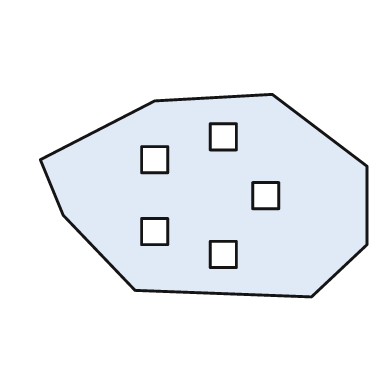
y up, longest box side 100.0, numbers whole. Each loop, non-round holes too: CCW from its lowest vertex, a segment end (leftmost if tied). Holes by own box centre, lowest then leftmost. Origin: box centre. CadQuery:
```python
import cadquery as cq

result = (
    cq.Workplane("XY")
    .moveTo(33.0, -31.0)
    .lineTo(50.0, -15.0)
    .lineTo(50.0, 9.0)
    .lineTo(21.0, 31.0)
    .lineTo(-15.0, 29.0)
    .lineTo(-50.0, 11.0)
    .lineTo(-43.0, -6.0)
    .lineTo(-21.0, -29.0)
    .close()
    .moveTo(2.0, -22.0)
    .lineTo(10.0, -22.0)
    .lineTo(10.0, -14.0)
    .lineTo(2.0, -14.0)
    .close()
    .moveTo(-19.0, -15.0)
    .lineTo(-11.0, -15.0)
    .lineTo(-11.0, -7.0)
    .lineTo(-19.0, -7.0)
    .close()
    .moveTo(15.0, -4.0)
    .lineTo(23.0, -4.0)
    .lineTo(23.0, 4.0)
    .lineTo(15.0, 4.0)
    .close()
    .moveTo(-19.0, 7.0)
    .lineTo(-11.0, 7.0)
    .lineTo(-11.0, 15.0)
    .lineTo(-19.0, 15.0)
    .close()
    .moveTo(2.0, 14.0)
    .lineTo(10.0, 14.0)
    .lineTo(10.0, 22.0)
    .lineTo(2.0, 22.0)
    .close()
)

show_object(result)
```